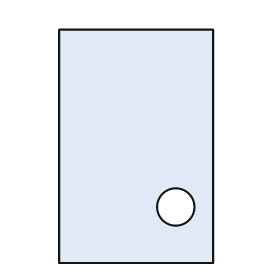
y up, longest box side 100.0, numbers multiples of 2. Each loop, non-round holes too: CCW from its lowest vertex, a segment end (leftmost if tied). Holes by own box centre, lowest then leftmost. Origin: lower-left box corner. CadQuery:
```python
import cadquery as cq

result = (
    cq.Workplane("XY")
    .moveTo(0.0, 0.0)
    .lineTo(66.0, 0.0)
    .lineTo(66.0, 100.0)
    .lineTo(0.0, 100.0)
    .close()
    .moveTo(50.0, 24.0)
    .circle(8.0)
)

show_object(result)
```